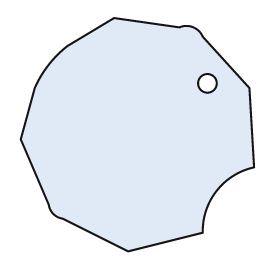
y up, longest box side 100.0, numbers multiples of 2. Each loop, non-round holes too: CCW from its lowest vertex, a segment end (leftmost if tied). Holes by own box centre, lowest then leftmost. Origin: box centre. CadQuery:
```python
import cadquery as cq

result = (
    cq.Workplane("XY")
    .moveTo(-4.0, -50.0)
    .lineTo(28.0, -42.0)
    .threePointArc((34.0, -24.0), (50.0, -14.0))
    .lineTo(48.0, 20.0)
    .lineTo(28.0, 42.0)
    .threePointArc((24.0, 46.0), (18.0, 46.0))
    .lineTo(-10.0, 50.0)
    .lineTo(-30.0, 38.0)
    .threePointArc((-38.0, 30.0), (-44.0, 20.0))
    .lineTo(-50.0, -2.0)
    .lineTo(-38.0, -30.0)
    .threePointArc((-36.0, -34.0), (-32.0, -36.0))
    .close()
    .moveTo(30.0, 22.0)
    .circle(4.0)
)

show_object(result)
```